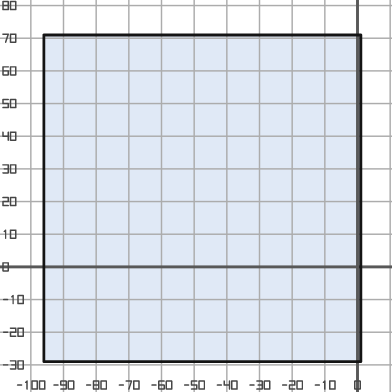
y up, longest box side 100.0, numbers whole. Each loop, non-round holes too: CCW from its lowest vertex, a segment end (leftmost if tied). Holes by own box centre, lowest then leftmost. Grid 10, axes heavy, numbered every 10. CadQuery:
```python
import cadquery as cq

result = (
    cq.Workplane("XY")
    .moveTo(-96.0, -29.0)
    .lineTo(1.0, -29.0)
    .lineTo(1.0, 71.0)
    .lineTo(-96.0, 71.0)
    .close()
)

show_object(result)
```